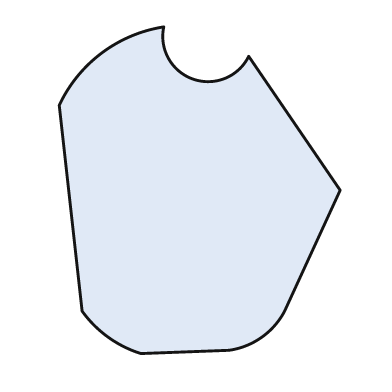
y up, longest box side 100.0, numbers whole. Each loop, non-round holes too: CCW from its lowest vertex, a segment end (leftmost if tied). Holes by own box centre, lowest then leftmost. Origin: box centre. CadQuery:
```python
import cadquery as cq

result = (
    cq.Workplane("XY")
    .moveTo(-18.0, -50.0)
    .lineTo(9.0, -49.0)
    .threePointArc((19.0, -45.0), (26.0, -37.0))
    .lineTo(43.0, 0.0)
    .lineTo(15.0, 41.0)
    .threePointArc((-2.0, 34.0), (-11.0, 50.0))
    .threePointArc((-30.0, 42.0), (-43.0, 26.0))
    .lineTo(-36.0, -37.0)
    .threePointArc((-28.0, -45.0), (-18.0, -50.0))
    .close()
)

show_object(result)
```